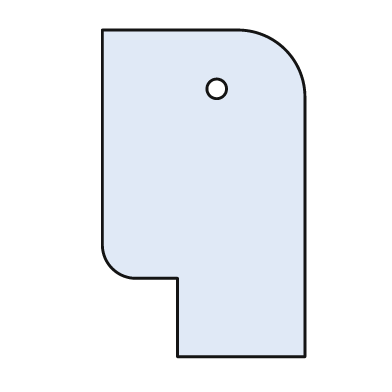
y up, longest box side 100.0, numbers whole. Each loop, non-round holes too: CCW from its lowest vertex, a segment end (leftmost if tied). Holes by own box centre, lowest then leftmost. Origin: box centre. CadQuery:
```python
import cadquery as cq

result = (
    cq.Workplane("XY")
    .moveTo(-8.0, -50.0)
    .lineTo(31.0, -50.0)
    .lineTo(31.0, 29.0)
    .threePointArc((25.0, 44.0), (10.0, 50.0))
    .lineTo(-31.0, 50.0)
    .lineTo(-31.0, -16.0)
    .threePointArc((-28.0, -23.0), (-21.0, -26.0))
    .lineTo(-8.0, -26.0)
    .close()
    .moveTo(4.0, 32.0)
    .circle(3.0)
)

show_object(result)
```